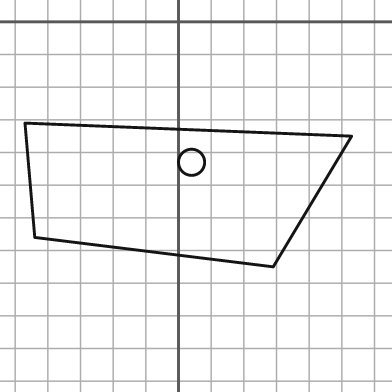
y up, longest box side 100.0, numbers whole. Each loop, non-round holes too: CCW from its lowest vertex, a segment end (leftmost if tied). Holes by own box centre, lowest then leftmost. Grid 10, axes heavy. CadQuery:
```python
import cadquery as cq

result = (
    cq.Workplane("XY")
    .moveTo(29.0, -75.0)
    .lineTo(53.0, -35.0)
    .lineTo(-47.0, -31.0)
    .lineTo(-44.0, -66.0)
    .close()
    .moveTo(4.0, -43.0)
    .circle(4.0)
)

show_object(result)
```